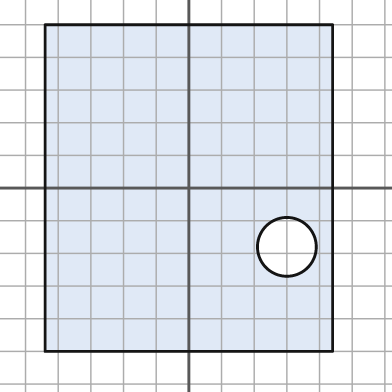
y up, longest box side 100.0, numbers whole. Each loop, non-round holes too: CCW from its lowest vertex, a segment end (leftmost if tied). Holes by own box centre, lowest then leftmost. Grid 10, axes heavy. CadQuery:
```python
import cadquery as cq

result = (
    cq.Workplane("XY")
    .moveTo(-44.0, -50.0)
    .lineTo(44.0, -50.0)
    .lineTo(44.0, 50.0)
    .lineTo(-44.0, 50.0)
    .close()
    .moveTo(30.0, -18.0)
    .circle(9.0)
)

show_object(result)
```